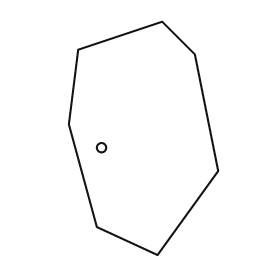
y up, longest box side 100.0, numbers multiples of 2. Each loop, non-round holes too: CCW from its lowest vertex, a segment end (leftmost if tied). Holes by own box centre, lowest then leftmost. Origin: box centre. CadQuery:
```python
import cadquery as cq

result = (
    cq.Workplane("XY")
    .moveTo(6.0, -50.0)
    .lineTo(32.0, -14.0)
    .lineTo(22.0, 36.0)
    .lineTo(8.0, 50.0)
    .lineTo(-28.0, 38.0)
    .lineTo(-32.0, 6.0)
    .lineTo(-20.0, -38.0)
    .close()
    .moveTo(-18.0, -4.0)
    .circle(2.0)
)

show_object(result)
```